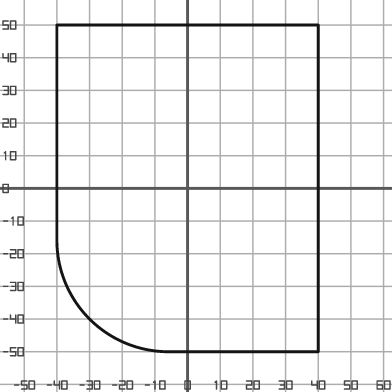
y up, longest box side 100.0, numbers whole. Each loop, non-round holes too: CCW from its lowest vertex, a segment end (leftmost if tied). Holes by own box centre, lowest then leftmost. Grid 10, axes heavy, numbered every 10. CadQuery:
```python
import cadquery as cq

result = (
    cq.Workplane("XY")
    .moveTo(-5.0, -50.0)
    .lineTo(40.0, -50.0)
    .lineTo(40.0, 50.0)
    .lineTo(-40.0, 50.0)
    .lineTo(-40.0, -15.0)
    .threePointArc((-30.0, -40.0), (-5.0, -50.0))
    .close()
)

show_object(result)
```